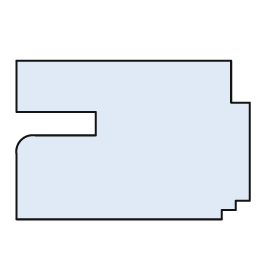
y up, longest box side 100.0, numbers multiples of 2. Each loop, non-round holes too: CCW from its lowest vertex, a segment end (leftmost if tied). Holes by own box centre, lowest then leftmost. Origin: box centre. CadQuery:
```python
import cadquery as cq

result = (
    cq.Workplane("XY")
    .moveTo(-50.0, -34.0)
    .lineTo(38.0, -34.0)
    .lineTo(38.0, -30.0)
    .lineTo(44.0, -30.0)
    .lineTo(44.0, -26.0)
    .lineTo(50.0, -26.0)
    .lineTo(50.0, 16.0)
    .lineTo(42.0, 16.0)
    .lineTo(42.0, 34.0)
    .lineTo(-50.0, 34.0)
    .lineTo(-50.0, 12.0)
    .lineTo(-16.0, 12.0)
    .lineTo(-16.0, 2.0)
    .lineTo(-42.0, 2.0)
    .threePointArc((-48.0, 0.0), (-50.0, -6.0))
    .close()
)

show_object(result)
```